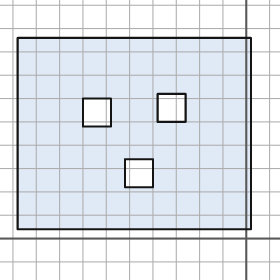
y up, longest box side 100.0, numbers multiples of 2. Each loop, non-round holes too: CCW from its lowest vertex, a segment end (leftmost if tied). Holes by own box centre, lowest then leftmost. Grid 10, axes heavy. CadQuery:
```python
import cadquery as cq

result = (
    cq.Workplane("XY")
    .moveTo(-98.0, 4.0)
    .lineTo(2.0, 4.0)
    .lineTo(2.0, 86.0)
    .lineTo(-98.0, 86.0)
    .close()
    .moveTo(-52.0, 22.0)
    .lineTo(-40.0, 22.0)
    .lineTo(-40.0, 34.0)
    .lineTo(-52.0, 34.0)
    .close()
    .moveTo(-70.0, 48.0)
    .lineTo(-58.0, 48.0)
    .lineTo(-58.0, 60.0)
    .lineTo(-70.0, 60.0)
    .close()
    .moveTo(-38.0, 50.0)
    .lineTo(-26.0, 50.0)
    .lineTo(-26.0, 62.0)
    .lineTo(-38.0, 62.0)
    .close()
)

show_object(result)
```